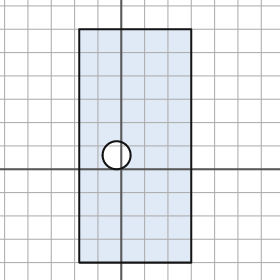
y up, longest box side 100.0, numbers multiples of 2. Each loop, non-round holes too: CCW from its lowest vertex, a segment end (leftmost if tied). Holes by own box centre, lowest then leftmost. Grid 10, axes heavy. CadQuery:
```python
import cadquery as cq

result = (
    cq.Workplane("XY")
    .moveTo(-18.0, -40.0)
    .lineTo(30.0, -40.0)
    .lineTo(30.0, 60.0)
    .lineTo(-18.0, 60.0)
    .close()
    .moveTo(-2.0, 6.0)
    .circle(6.0)
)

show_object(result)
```